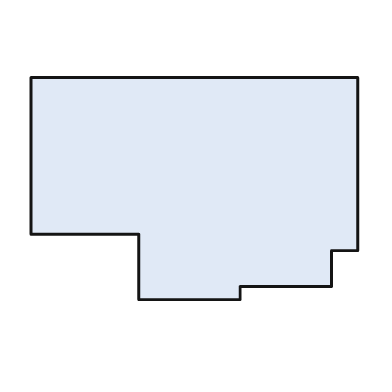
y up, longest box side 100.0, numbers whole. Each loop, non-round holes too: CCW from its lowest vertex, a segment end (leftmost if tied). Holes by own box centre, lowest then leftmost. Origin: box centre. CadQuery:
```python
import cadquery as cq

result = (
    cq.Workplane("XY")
    .moveTo(-17.0, -34.0)
    .lineTo(14.0, -34.0)
    .lineTo(14.0, -30.0)
    .lineTo(42.0, -30.0)
    .lineTo(42.0, -19.0)
    .lineTo(50.0, -19.0)
    .lineTo(50.0, 34.0)
    .lineTo(-50.0, 34.0)
    .lineTo(-50.0, -14.0)
    .lineTo(-17.0, -14.0)
    .close()
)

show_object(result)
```